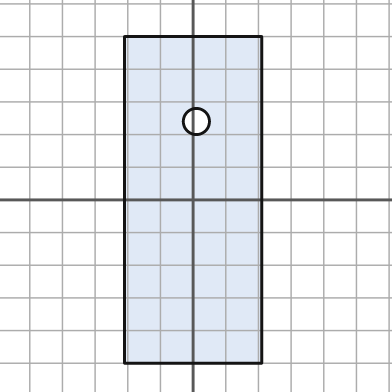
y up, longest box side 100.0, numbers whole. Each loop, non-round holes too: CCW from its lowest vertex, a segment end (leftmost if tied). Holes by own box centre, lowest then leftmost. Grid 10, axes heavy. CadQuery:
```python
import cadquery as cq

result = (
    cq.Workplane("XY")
    .moveTo(-21.0, -50.0)
    .lineTo(21.0, -50.0)
    .lineTo(21.0, 50.0)
    .lineTo(-21.0, 50.0)
    .close()
    .moveTo(1.0, 24.0)
    .circle(4.0)
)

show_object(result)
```